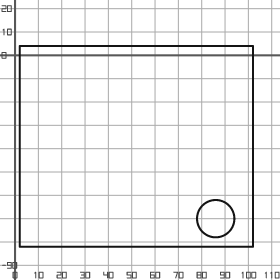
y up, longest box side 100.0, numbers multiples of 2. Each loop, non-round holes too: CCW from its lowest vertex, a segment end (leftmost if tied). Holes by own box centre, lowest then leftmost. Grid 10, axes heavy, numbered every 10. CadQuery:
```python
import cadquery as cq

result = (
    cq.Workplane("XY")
    .moveTo(2.0, -82.0)
    .lineTo(102.0, -82.0)
    .lineTo(102.0, 4.0)
    .lineTo(2.0, 4.0)
    .close()
    .moveTo(86.0, -70.0)
    .circle(8.0)
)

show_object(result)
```